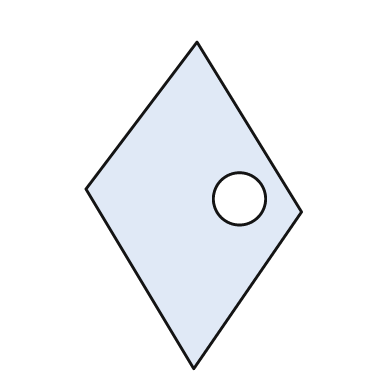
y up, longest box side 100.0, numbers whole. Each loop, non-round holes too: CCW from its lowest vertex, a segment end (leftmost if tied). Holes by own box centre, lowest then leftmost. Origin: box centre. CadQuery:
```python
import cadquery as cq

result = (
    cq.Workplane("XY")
    .moveTo(0.0, -50.0)
    .lineTo(33.0, -2.0)
    .lineTo(1.0, 50.0)
    .lineTo(-33.0, 5.0)
    .close()
    .moveTo(14.0, 2.0)
    .circle(8.0)
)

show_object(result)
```